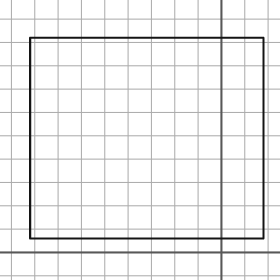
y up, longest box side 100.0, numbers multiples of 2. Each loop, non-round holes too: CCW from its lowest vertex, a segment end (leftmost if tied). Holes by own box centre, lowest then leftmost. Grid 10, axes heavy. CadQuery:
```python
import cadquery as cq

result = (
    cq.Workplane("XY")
    .moveTo(-82.0, 6.0)
    .lineTo(18.0, 6.0)
    .lineTo(18.0, 92.0)
    .lineTo(-82.0, 92.0)
    .close()
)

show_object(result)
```